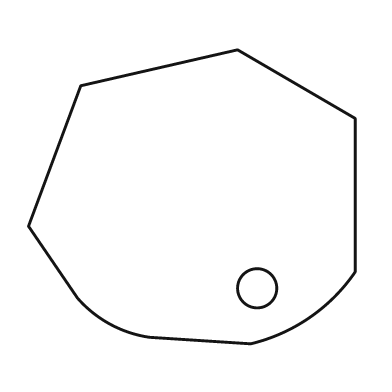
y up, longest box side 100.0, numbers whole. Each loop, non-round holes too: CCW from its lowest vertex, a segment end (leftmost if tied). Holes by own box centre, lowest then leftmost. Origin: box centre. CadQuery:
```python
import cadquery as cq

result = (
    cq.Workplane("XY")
    .moveTo(18.0, -45.0)
    .threePointArc((36.0, -37.0), (50.0, -23.0))
    .lineTo(50.0, 24.0)
    .lineTo(14.0, 45.0)
    .lineTo(-34.0, 34.0)
    .lineTo(-50.0, -9.0)
    .lineTo(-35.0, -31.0)
    .threePointArc((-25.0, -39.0), (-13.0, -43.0))
    .close()
    .moveTo(20.0, -28.0)
    .circle(6.0)
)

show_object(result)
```